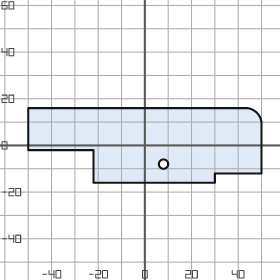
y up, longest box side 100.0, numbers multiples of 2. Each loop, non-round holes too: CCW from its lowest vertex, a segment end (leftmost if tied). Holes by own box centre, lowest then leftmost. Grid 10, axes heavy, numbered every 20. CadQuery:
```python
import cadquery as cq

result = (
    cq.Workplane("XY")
    .moveTo(-22.0, -16.0)
    .lineTo(30.0, -16.0)
    .lineTo(30.0, -12.0)
    .lineTo(50.0, -12.0)
    .lineTo(50.0, 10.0)
    .threePointArc((48.0, 14.0), (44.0, 16.0))
    .lineTo(-50.0, 16.0)
    .lineTo(-50.0, -2.0)
    .lineTo(-22.0, -2.0)
    .close()
    .moveTo(8.0, -8.0)
    .circle(2.0)
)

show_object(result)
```